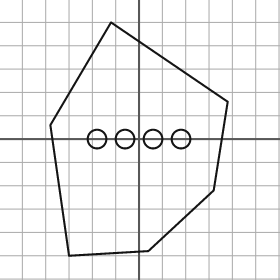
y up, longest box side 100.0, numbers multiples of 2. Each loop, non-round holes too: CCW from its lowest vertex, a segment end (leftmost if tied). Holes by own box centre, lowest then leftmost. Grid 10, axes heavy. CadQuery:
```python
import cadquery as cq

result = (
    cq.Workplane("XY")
    .moveTo(-30.0, -50.0)
    .lineTo(4.0, -48.0)
    .lineTo(32.0, -22.0)
    .lineTo(38.0, 16.0)
    .lineTo(-12.0, 50.0)
    .lineTo(-38.0, 6.0)
    .close()
    .moveTo(-18.0, 0.0)
    .circle(4.0)
    .moveTo(-6.0, 0.0)
    .circle(4.0)
    .moveTo(6.0, 0.0)
    .circle(4.0)
    .moveTo(18.0, 0.0)
    .circle(4.0)
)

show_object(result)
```